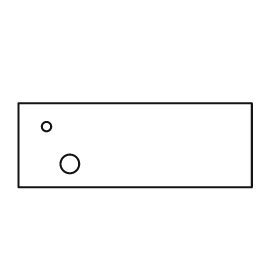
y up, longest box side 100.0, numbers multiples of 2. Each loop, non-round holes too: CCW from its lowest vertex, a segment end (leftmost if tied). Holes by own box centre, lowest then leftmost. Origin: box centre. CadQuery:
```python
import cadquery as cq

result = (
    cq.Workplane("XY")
    .moveTo(-50.0, -18.0)
    .lineTo(50.0, -18.0)
    .lineTo(50.0, 18.0)
    .lineTo(-50.0, 18.0)
    .close()
    .moveTo(-28.0, -8.0)
    .circle(4.0)
    .moveTo(-38.0, 8.0)
    .circle(2.0)
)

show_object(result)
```